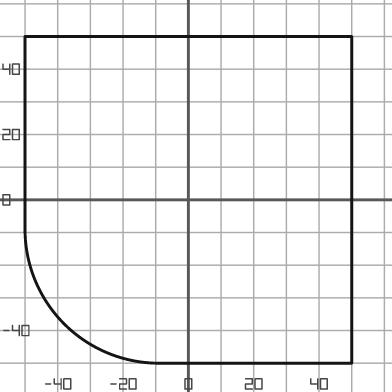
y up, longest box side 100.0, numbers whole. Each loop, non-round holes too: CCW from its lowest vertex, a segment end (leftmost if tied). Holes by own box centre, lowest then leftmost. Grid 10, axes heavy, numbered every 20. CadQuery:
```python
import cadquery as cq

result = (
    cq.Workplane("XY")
    .moveTo(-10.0, -50.0)
    .lineTo(50.0, -50.0)
    .lineTo(50.0, 50.0)
    .lineTo(-50.0, 50.0)
    .lineTo(-50.0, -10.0)
    .threePointArc((-38.0, -38.0), (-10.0, -50.0))
    .close()
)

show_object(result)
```